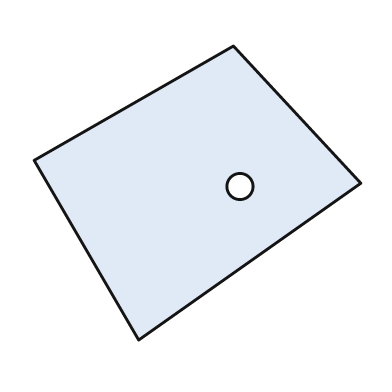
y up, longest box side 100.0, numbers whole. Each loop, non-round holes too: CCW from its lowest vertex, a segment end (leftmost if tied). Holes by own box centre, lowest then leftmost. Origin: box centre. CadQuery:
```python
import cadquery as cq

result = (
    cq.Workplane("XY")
    .moveTo(-18.0, -45.0)
    .lineTo(50.0, 3.0)
    .lineTo(11.0, 45.0)
    .lineTo(-50.0, 10.0)
    .close()
    .moveTo(13.0, 2.0)
    .circle(4.0)
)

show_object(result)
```